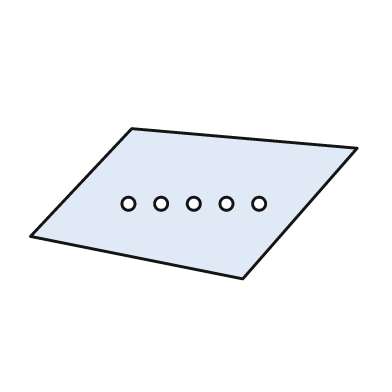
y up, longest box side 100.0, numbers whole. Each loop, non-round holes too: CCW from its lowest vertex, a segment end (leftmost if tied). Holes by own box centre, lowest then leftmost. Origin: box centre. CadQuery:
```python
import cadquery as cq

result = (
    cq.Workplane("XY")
    .moveTo(15.0, -23.0)
    .lineTo(50.0, 17.0)
    .lineTo(-19.0, 23.0)
    .lineTo(-50.0, -10.0)
    .close()
    .moveTo(-20.0, 0.0)
    .circle(2.0)
    .moveTo(-10.0, 0.0)
    .circle(2.0)
    .moveTo(0.0, 0.0)
    .circle(2.0)
    .moveTo(10.0, 0.0)
    .circle(2.0)
    .moveTo(20.0, 0.0)
    .circle(2.0)
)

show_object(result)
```